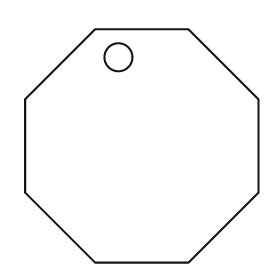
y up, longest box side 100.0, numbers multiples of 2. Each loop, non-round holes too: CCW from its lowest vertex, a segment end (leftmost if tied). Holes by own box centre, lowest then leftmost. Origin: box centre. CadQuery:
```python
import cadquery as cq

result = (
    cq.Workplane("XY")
    .moveTo(-20.0, -50.0)
    .lineTo(20.0, -50.0)
    .lineTo(50.0, -20.0)
    .lineTo(50.0, 20.0)
    .lineTo(20.0, 50.0)
    .lineTo(-20.0, 50.0)
    .lineTo(-50.0, 20.0)
    .lineTo(-50.0, -20.0)
    .close()
    .moveTo(-10.0, 38.0)
    .circle(6.0)
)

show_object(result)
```